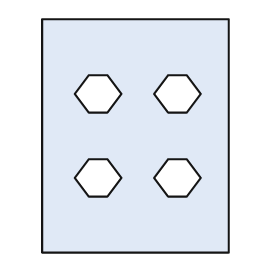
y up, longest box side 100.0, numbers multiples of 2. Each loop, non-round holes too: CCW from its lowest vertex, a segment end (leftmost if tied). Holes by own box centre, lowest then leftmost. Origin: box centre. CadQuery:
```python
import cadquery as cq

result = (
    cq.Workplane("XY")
    .moveTo(-40.0, -50.0)
    .lineTo(40.0, -50.0)
    .lineTo(40.0, 50.0)
    .lineTo(-40.0, 50.0)
    .close()
    .moveTo(-20.0, -26.0)
    .lineTo(-12.0, -26.0)
    .lineTo(-6.0, -18.0)
    .lineTo(-12.0, -10.0)
    .lineTo(-20.0, -10.0)
    .lineTo(-26.0, -18.0)
    .close()
    .moveTo(14.0, -26.0)
    .lineTo(22.0, -26.0)
    .lineTo(28.0, -18.0)
    .lineTo(22.0, -10.0)
    .lineTo(14.0, -10.0)
    .lineTo(8.0, -18.0)
    .close()
    .moveTo(-20.0, 10.0)
    .lineTo(-12.0, 10.0)
    .lineTo(-6.0, 18.0)
    .lineTo(-12.0, 26.0)
    .lineTo(-20.0, 26.0)
    .lineTo(-26.0, 18.0)
    .close()
    .moveTo(14.0, 10.0)
    .lineTo(22.0, 10.0)
    .lineTo(28.0, 18.0)
    .lineTo(22.0, 26.0)
    .lineTo(14.0, 26.0)
    .lineTo(8.0, 18.0)
    .close()
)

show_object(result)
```